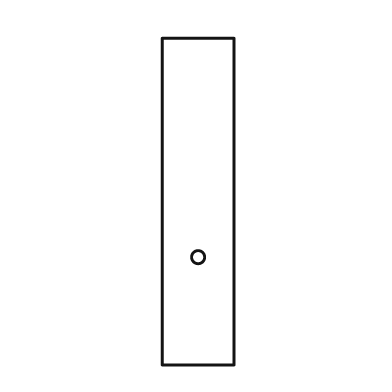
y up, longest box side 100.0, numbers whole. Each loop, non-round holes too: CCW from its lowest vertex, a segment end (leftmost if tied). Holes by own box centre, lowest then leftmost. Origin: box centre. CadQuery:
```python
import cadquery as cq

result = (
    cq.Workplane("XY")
    .moveTo(-11.0, -50.0)
    .lineTo(11.0, -50.0)
    .lineTo(11.0, 50.0)
    .lineTo(-11.0, 50.0)
    .close()
    .moveTo(0.0, -17.0)
    .circle(2.0)
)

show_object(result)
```